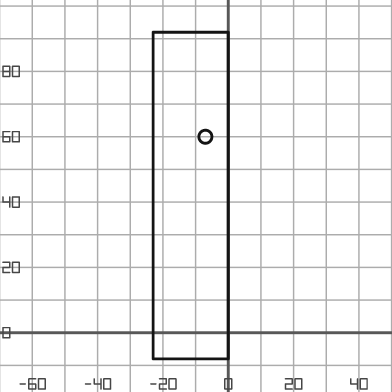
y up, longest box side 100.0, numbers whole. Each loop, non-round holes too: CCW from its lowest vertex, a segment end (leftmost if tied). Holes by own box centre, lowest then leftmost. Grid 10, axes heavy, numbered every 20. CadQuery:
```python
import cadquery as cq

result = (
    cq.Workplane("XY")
    .moveTo(-23.0, -8.0)
    .lineTo(0.0, -8.0)
    .lineTo(0.0, 92.0)
    .lineTo(-23.0, 92.0)
    .close()
    .moveTo(-7.0, 60.0)
    .circle(2.0)
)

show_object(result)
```